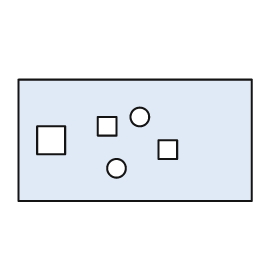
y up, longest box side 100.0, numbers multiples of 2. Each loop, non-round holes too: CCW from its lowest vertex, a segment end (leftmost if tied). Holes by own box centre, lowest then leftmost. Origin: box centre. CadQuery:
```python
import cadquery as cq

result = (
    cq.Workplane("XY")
    .moveTo(-50.0, -26.0)
    .lineTo(50.0, -26.0)
    .lineTo(50.0, 26.0)
    .lineTo(-50.0, 26.0)
    .close()
    .moveTo(-8.0, -12.0)
    .circle(4.0)
    .moveTo(10.0, -8.0)
    .lineTo(18.0, -8.0)
    .lineTo(18.0, 0.0)
    .lineTo(10.0, 0.0)
    .close()
    .moveTo(-42.0, -6.0)
    .lineTo(-30.0, -6.0)
    .lineTo(-30.0, 6.0)
    .lineTo(-42.0, 6.0)
    .close()
    .moveTo(-16.0, 2.0)
    .lineTo(-8.0, 2.0)
    .lineTo(-8.0, 10.0)
    .lineTo(-16.0, 10.0)
    .close()
    .moveTo(2.0, 10.0)
    .circle(4.0)
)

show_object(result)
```